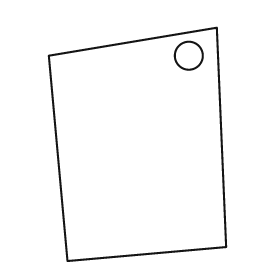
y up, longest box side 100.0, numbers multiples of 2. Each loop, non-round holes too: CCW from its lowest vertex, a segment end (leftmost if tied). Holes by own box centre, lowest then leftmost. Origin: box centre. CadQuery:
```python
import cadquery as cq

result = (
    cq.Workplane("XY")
    .moveTo(-30.0, -50.0)
    .lineTo(38.0, -44.0)
    .lineTo(34.0, 50.0)
    .lineTo(-38.0, 38.0)
    .close()
    .moveTo(22.0, 38.0)
    .circle(6.0)
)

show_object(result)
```